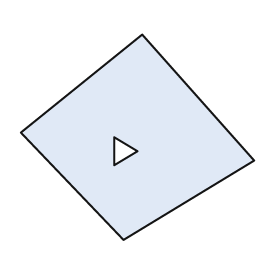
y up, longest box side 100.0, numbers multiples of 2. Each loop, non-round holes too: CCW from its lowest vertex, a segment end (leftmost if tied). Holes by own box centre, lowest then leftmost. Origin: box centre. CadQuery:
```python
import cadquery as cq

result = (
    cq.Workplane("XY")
    .moveTo(-6.0, -44.0)
    .lineTo(50.0, -10.0)
    .lineTo(2.0, 44.0)
    .lineTo(-50.0, 2.0)
    .close()
    .moveTo(-10.0, -12.0)
    .lineTo(0.0, -6.0)
    .lineTo(-10.0, 0.0)
    .close()
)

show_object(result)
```